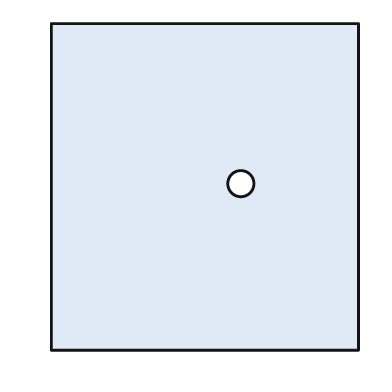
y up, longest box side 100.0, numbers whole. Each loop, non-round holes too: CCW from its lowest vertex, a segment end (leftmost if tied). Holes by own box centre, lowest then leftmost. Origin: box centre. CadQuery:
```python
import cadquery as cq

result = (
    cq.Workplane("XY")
    .moveTo(-47.0, -50.0)
    .lineTo(47.0, -50.0)
    .lineTo(47.0, 50.0)
    .lineTo(-47.0, 50.0)
    .close()
    .moveTo(11.0, 1.0)
    .circle(4.0)
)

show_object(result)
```